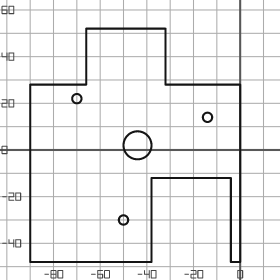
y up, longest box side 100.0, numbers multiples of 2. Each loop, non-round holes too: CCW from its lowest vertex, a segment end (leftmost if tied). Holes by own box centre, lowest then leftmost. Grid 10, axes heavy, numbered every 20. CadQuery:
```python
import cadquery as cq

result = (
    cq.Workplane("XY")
    .moveTo(-90.0, -48.0)
    .lineTo(-38.0, -48.0)
    .lineTo(-38.0, -12.0)
    .lineTo(-4.0, -12.0)
    .lineTo(-4.0, -48.0)
    .lineTo(0.0, -48.0)
    .lineTo(0.0, 28.0)
    .lineTo(-32.0, 28.0)
    .lineTo(-32.0, 52.0)
    .lineTo(-66.0, 52.0)
    .lineTo(-66.0, 28.0)
    .lineTo(-90.0, 28.0)
    .close()
    .moveTo(-50.0, -30.0)
    .circle(2.0)
    .moveTo(-44.0, 2.0)
    .circle(6.0)
    .moveTo(-14.0, 14.0)
    .circle(2.0)
    .moveTo(-70.0, 22.0)
    .circle(2.0)
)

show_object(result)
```